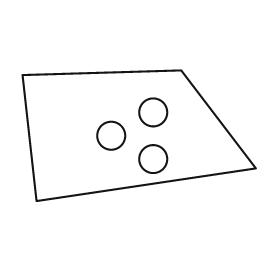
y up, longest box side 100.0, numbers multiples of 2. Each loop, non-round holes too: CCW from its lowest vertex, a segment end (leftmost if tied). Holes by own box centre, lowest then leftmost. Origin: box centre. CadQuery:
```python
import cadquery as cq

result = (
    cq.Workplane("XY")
    .moveTo(-44.0, -28.0)
    .lineTo(50.0, -14.0)
    .lineTo(18.0, 28.0)
    .lineTo(-50.0, 26.0)
    .close()
    .moveTo(6.0, -10.0)
    .circle(6.0)
    .moveTo(-12.0, 0.0)
    .circle(6.0)
    .moveTo(6.0, 10.0)
    .circle(6.0)
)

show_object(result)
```